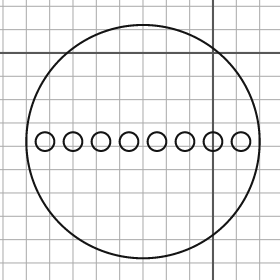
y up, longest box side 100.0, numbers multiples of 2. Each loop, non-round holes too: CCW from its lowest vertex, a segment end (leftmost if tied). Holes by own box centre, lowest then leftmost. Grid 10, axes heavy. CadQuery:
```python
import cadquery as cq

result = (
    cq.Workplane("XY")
    .moveTo(-30.0, -38.0)
    .circle(50.0)
    .moveTo(-72.0, -38.0)
    .circle(4.0)
    .moveTo(-60.0, -38.0)
    .circle(4.0)
    .moveTo(-48.0, -38.0)
    .circle(4.0)
    .moveTo(-36.0, -38.0)
    .circle(4.0)
    .moveTo(-24.0, -38.0)
    .circle(4.0)
    .moveTo(-12.0, -38.0)
    .circle(4.0)
    .moveTo(0.0, -38.0)
    .circle(4.0)
    .moveTo(12.0, -38.0)
    .circle(4.0)
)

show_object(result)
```